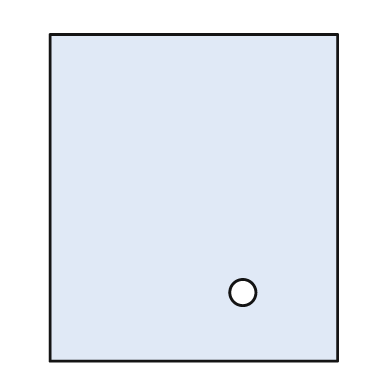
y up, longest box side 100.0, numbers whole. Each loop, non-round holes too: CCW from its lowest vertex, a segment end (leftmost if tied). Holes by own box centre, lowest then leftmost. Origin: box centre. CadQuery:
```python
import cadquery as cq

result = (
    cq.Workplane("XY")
    .moveTo(-44.0, -50.0)
    .lineTo(44.0, -50.0)
    .lineTo(44.0, 50.0)
    .lineTo(-44.0, 50.0)
    .close()
    .moveTo(15.0, -29.0)
    .circle(4.0)
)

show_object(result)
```